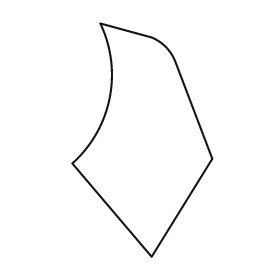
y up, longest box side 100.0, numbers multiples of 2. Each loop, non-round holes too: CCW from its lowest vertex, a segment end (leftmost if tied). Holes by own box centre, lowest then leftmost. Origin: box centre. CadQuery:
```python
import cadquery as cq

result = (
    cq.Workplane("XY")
    .moveTo(4.0, -50.0)
    .lineTo(30.0, -8.0)
    .lineTo(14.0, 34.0)
    .threePointArc((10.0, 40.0), (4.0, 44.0))
    .lineTo(-18.0, 50.0)
    .threePointArc((-14.0, 18.0), (-30.0, -10.0))
    .close()
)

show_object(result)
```